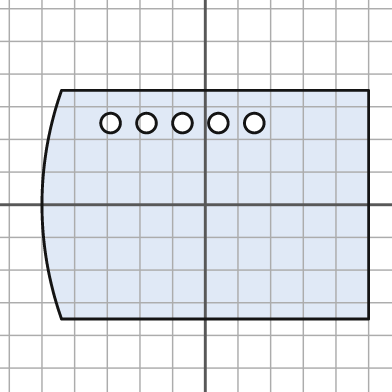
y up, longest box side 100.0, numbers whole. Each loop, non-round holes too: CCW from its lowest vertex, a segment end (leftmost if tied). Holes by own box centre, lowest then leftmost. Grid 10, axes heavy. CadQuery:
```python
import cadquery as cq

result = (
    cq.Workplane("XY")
    .moveTo(-44.0, -35.0)
    .lineTo(50.0, -35.0)
    .lineTo(50.0, 35.0)
    .lineTo(-44.0, 35.0)
    .threePointArc((-50.0, 0.0), (-44.0, -35.0))
    .close()
    .moveTo(-29.0, 25.0)
    .circle(3.0)
    .moveTo(-18.0, 25.0)
    .circle(3.0)
    .moveTo(-7.0, 25.0)
    .circle(3.0)
    .moveTo(4.0, 25.0)
    .circle(3.0)
    .moveTo(15.0, 25.0)
    .circle(3.0)
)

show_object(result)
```